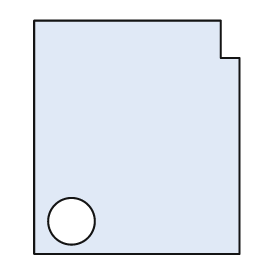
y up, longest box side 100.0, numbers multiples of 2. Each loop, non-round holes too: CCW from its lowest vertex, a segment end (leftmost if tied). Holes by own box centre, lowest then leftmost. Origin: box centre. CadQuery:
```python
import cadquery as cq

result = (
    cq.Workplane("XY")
    .moveTo(-44.0, -50.0)
    .lineTo(44.0, -50.0)
    .lineTo(44.0, 34.0)
    .lineTo(36.0, 34.0)
    .lineTo(36.0, 50.0)
    .lineTo(-44.0, 50.0)
    .close()
    .moveTo(-28.0, -36.0)
    .circle(10.0)
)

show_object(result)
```